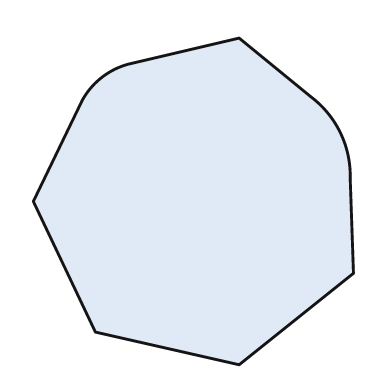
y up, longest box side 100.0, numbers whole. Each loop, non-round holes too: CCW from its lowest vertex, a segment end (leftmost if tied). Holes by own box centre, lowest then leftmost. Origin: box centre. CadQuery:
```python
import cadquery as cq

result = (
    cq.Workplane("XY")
    .moveTo(14.0, -50.0)
    .lineTo(49.0, -22.0)
    .lineTo(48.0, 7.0)
    .threePointArc((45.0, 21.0), (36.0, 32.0))
    .lineTo(14.0, 50.0)
    .lineTo(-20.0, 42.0)
    .threePointArc((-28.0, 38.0), (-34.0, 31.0))
    .lineTo(-49.0, 0.0)
    .lineTo(-30.0, -40.0)
    .close()
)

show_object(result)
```